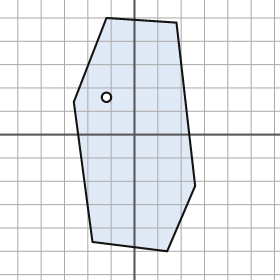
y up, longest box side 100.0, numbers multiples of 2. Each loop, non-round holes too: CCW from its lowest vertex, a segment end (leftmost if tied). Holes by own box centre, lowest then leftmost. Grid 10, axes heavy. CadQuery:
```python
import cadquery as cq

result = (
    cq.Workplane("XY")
    .moveTo(14.0, -50.0)
    .lineTo(26.0, -22.0)
    .lineTo(18.0, 48.0)
    .lineTo(-12.0, 50.0)
    .lineTo(-26.0, 14.0)
    .lineTo(-18.0, -46.0)
    .close()
    .moveTo(-12.0, 16.0)
    .circle(2.0)
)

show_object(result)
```